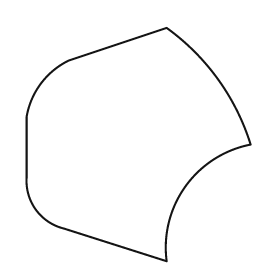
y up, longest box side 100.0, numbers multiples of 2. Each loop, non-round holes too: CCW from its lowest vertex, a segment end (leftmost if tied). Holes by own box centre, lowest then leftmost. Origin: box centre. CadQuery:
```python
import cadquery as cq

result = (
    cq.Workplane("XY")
    .moveTo(12.0, -50.0)
    .threePointArc((20.0, -18.0), (48.0, 0.0))
    .threePointArc((34.0, 28.0), (12.0, 50.0))
    .lineTo(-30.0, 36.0)
    .threePointArc((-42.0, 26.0), (-48.0, 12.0))
    .lineTo(-48.0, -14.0)
    .threePointArc((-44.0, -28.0), (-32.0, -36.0))
    .close()
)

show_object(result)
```